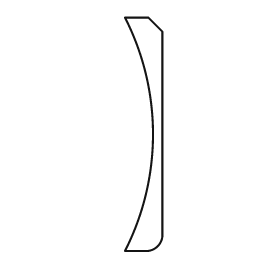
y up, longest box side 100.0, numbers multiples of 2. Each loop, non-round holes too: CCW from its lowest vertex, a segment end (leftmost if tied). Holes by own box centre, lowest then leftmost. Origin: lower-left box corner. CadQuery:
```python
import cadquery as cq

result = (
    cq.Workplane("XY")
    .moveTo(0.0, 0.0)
    .lineTo(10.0, 0.0)
    .threePointArc((14.0, 2.0), (16.0, 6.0))
    .lineTo(16.0, 94.0)
    .lineTo(10.0, 100.0)
    .lineTo(0.0, 100.0)
    .threePointArc((12.0, 50.0), (0.0, 0.0))
    .close()
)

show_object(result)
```